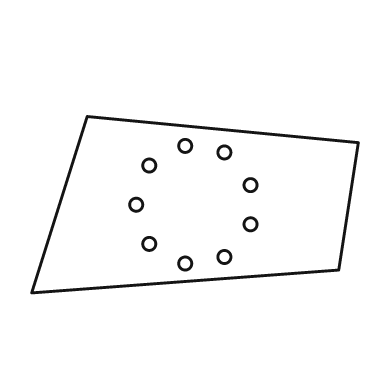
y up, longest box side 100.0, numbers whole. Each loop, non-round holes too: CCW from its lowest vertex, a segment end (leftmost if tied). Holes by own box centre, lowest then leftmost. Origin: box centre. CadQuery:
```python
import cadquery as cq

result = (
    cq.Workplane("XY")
    .moveTo(-50.0, -27.0)
    .lineTo(44.0, -20.0)
    .lineTo(50.0, 19.0)
    .lineTo(-33.0, 27.0)
    .close()
    .moveTo(-3.0, -18.0)
    .circle(2.0)
    .moveTo(9.0, -16.0)
    .circle(2.0)
    .moveTo(-14.0, -12.0)
    .circle(2.0)
    .moveTo(17.0, -6.0)
    .circle(2.0)
    .moveTo(-18.0, 0.0)
    .circle(2.0)
    .moveTo(17.0, 6.0)
    .circle(2.0)
    .moveTo(-14.0, 12.0)
    .circle(2.0)
    .moveTo(9.0, 16.0)
    .circle(2.0)
    .moveTo(-3.0, 18.0)
    .circle(2.0)
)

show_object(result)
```